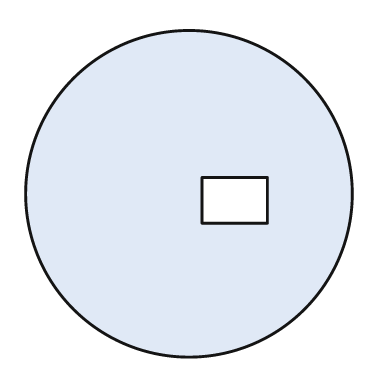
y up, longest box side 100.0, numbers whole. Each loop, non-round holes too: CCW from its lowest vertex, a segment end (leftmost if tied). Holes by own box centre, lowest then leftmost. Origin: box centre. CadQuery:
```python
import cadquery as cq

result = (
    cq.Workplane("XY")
    .moveTo(0.0, 0.0)
    .circle(50.0)
    .moveTo(4.0, -9.0)
    .lineTo(24.0, -9.0)
    .lineTo(24.0, 5.0)
    .lineTo(4.0, 5.0)
    .close()
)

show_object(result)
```